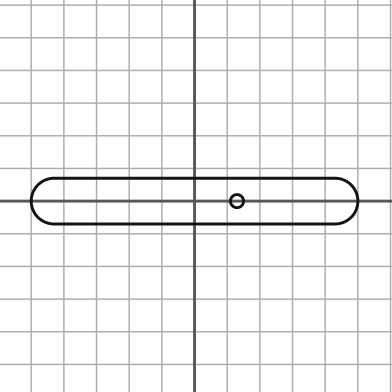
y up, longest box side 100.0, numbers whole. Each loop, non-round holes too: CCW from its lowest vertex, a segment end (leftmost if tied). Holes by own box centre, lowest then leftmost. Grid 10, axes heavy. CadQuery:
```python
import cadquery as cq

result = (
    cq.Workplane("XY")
    .moveTo(-43.0, -7.0)
    .lineTo(43.0, -7.0)
    .threePointArc((50.0, 0.0), (43.0, 7.0))
    .lineTo(-43.0, 7.0)
    .threePointArc((-50.0, 0.0), (-43.0, -7.0))
    .close()
    .moveTo(13.0, 0.0)
    .circle(2.0)
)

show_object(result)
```